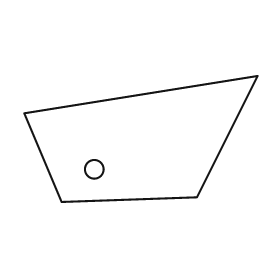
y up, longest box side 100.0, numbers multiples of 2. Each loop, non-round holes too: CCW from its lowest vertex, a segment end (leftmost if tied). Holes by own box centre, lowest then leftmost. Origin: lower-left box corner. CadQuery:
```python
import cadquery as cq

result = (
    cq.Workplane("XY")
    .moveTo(16.0, 0.0)
    .lineTo(74.0, 2.0)
    .lineTo(100.0, 54.0)
    .lineTo(0.0, 38.0)
    .close()
    .moveTo(30.0, 14.0)
    .circle(4.0)
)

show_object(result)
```